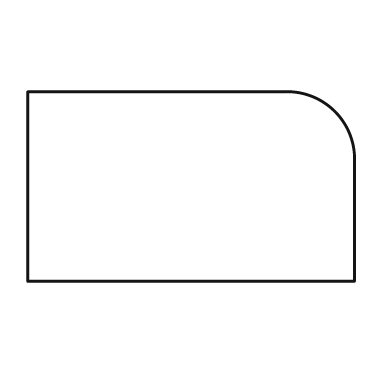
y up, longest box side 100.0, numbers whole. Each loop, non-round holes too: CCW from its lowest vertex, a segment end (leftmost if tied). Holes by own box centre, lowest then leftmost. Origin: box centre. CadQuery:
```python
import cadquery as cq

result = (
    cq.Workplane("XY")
    .moveTo(-50.0, -29.0)
    .lineTo(50.0, -29.0)
    .lineTo(50.0, 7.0)
    .threePointArc((44.0, 23.0), (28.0, 29.0))
    .lineTo(-50.0, 29.0)
    .close()
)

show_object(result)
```